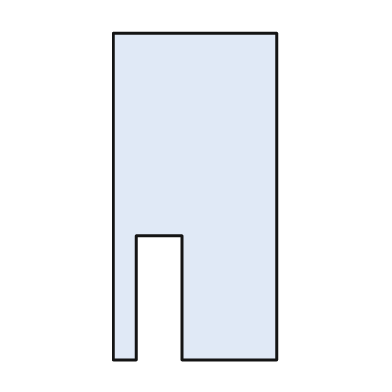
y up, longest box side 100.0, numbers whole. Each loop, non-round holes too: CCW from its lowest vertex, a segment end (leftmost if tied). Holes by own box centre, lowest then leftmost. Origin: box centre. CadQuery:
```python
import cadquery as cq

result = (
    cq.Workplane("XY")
    .moveTo(-25.0, -50.0)
    .lineTo(-18.0, -50.0)
    .lineTo(-18.0, -12.0)
    .lineTo(-4.0, -12.0)
    .lineTo(-4.0, -50.0)
    .lineTo(25.0, -50.0)
    .lineTo(25.0, 50.0)
    .lineTo(-25.0, 50.0)
    .close()
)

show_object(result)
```